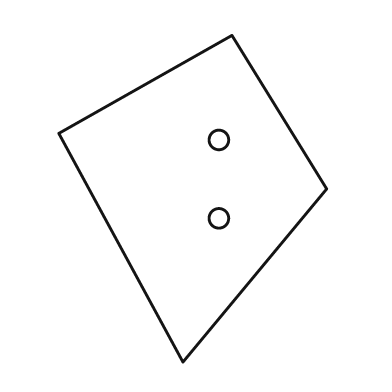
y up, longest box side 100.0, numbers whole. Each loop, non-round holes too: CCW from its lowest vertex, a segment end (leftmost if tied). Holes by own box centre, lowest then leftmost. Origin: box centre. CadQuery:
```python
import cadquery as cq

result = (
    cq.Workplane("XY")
    .moveTo(-3.0, -50.0)
    .lineTo(41.0, 3.0)
    .lineTo(12.0, 50.0)
    .lineTo(-41.0, 20.0)
    .close()
    .moveTo(8.0, -6.0)
    .circle(3.0)
    .moveTo(8.0, 18.0)
    .circle(3.0)
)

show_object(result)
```